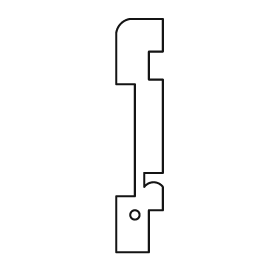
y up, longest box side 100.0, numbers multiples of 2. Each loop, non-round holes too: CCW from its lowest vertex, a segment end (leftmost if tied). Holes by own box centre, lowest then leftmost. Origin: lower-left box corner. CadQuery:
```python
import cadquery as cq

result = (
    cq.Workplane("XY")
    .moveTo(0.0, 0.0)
    .lineTo(14.0, 0.0)
    .lineTo(14.0, 18.0)
    .lineTo(20.0, 18.0)
    .lineTo(20.0, 28.0)
    .threePointArc((16.0, 30.0), (12.0, 28.0))
    .lineTo(12.0, 34.0)
    .lineTo(20.0, 34.0)
    .lineTo(20.0, 74.0)
    .lineTo(14.0, 74.0)
    .lineTo(14.0, 86.0)
    .lineTo(20.0, 86.0)
    .lineTo(20.0, 100.0)
    .lineTo(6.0, 100.0)
    .threePointArc((2.0, 98.0), (0.0, 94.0))
    .lineTo(0.0, 72.0)
    .lineTo(8.0, 72.0)
    .lineTo(8.0, 24.0)
    .lineTo(0.0, 24.0)
    .close()
    .moveTo(8.0, 16.0)
    .circle(2.0)
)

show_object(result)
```